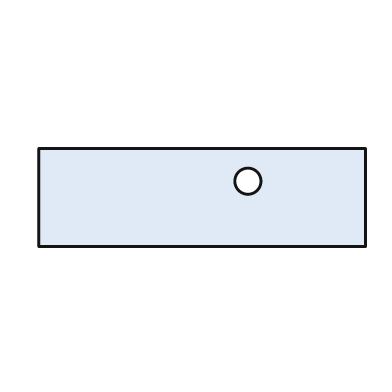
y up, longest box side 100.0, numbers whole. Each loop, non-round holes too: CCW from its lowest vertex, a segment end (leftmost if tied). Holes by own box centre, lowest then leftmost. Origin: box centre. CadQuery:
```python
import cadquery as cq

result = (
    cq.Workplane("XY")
    .moveTo(-50.0, -15.0)
    .lineTo(50.0, -15.0)
    .lineTo(50.0, 15.0)
    .lineTo(-50.0, 15.0)
    .close()
    .moveTo(14.0, 5.0)
    .circle(4.0)
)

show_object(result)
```